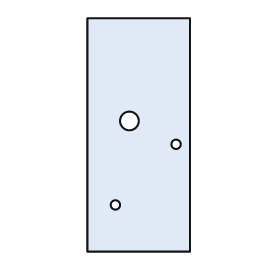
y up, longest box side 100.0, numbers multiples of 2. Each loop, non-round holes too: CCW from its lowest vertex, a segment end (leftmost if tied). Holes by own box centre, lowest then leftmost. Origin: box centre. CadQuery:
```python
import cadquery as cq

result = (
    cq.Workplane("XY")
    .moveTo(-22.0, -50.0)
    .lineTo(22.0, -50.0)
    .lineTo(22.0, 50.0)
    .lineTo(-22.0, 50.0)
    .close()
    .moveTo(-10.0, -30.0)
    .circle(2.0)
    .moveTo(16.0, -4.0)
    .circle(2.0)
    .moveTo(-4.0, 6.0)
    .circle(4.0)
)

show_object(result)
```